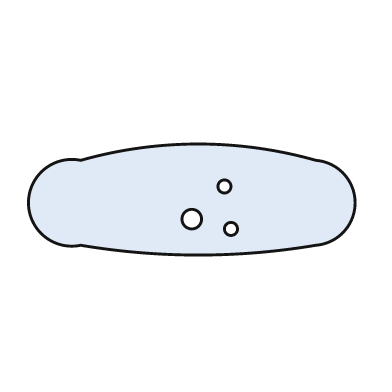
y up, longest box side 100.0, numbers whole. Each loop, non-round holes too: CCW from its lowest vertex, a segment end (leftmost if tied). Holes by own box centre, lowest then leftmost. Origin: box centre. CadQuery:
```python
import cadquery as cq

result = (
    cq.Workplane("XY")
    .moveTo(-34.0, -14.0)
    .threePointArc((2.0, -17.0), (38.0, -14.0))
    .threePointArc((50.0, -1.0), (38.0, 12.0))
    .threePointArc((2.0, 17.0), (-34.0, 12.0))
    .threePointArc((-50.0, -1.0), (-34.0, -14.0))
    .close()
    .moveTo(12.0, -9.0)
    .circle(2.0)
    .moveTo(0.0, -6.0)
    .circle(3.0)
    .moveTo(10.0, 4.0)
    .circle(2.0)
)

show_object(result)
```